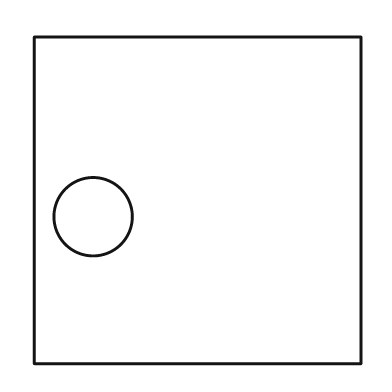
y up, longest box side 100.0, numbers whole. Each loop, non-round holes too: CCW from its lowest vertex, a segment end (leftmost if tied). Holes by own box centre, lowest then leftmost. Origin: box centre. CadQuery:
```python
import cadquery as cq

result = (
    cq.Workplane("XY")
    .moveTo(-50.0, -50.0)
    .lineTo(50.0, -50.0)
    .lineTo(50.0, 50.0)
    .lineTo(-50.0, 50.0)
    .close()
    .moveTo(-32.0, -5.0)
    .circle(12.0)
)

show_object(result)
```